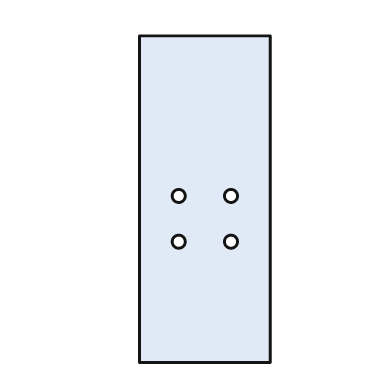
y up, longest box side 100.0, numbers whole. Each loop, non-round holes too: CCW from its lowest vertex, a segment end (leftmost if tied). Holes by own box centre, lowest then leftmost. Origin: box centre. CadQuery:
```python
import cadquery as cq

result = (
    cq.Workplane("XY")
    .moveTo(-20.0, -50.0)
    .lineTo(20.0, -50.0)
    .lineTo(20.0, 50.0)
    .lineTo(-20.0, 50.0)
    .close()
    .moveTo(-8.0, -13.0)
    .circle(2.0)
    .moveTo(8.0, -13.0)
    .circle(2.0)
    .moveTo(-8.0, 1.0)
    .circle(2.0)
    .moveTo(8.0, 1.0)
    .circle(2.0)
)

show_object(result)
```